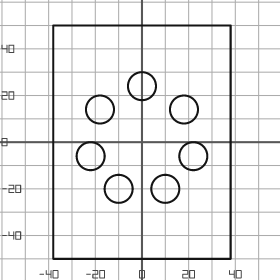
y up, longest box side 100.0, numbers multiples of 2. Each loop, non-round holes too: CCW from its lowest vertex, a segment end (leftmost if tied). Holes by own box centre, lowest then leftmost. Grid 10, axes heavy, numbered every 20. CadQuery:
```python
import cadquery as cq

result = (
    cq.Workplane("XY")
    .moveTo(-38.0, -50.0)
    .lineTo(38.0, -50.0)
    .lineTo(38.0, 50.0)
    .lineTo(-38.0, 50.0)
    .close()
    .moveTo(-10.0, -20.0)
    .circle(6.0)
    .moveTo(10.0, -20.0)
    .circle(6.0)
    .moveTo(-22.0, -6.0)
    .circle(6.0)
    .moveTo(22.0, -6.0)
    .circle(6.0)
    .moveTo(-18.0, 14.0)
    .circle(6.0)
    .moveTo(18.0, 14.0)
    .circle(6.0)
    .moveTo(0.0, 24.0)
    .circle(6.0)
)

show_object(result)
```